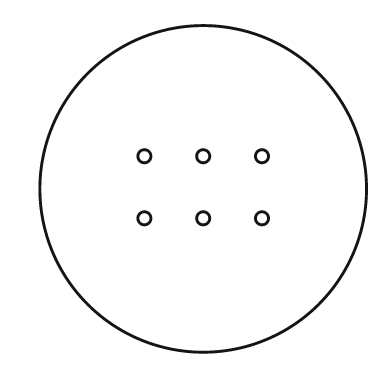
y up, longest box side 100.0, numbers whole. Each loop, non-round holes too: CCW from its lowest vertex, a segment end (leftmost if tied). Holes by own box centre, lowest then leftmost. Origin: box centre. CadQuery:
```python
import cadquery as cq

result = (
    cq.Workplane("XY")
    .moveTo(0.0, 0.0)
    .circle(50.0)
    .moveTo(-18.0, -9.0)
    .circle(2.0)
    .moveTo(0.0, -9.0)
    .circle(2.0)
    .moveTo(18.0, -9.0)
    .circle(2.0)
    .moveTo(-18.0, 10.0)
    .circle(2.0)
    .moveTo(0.0, 10.0)
    .circle(2.0)
    .moveTo(18.0, 10.0)
    .circle(2.0)
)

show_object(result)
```